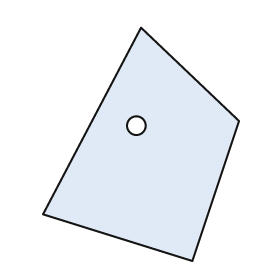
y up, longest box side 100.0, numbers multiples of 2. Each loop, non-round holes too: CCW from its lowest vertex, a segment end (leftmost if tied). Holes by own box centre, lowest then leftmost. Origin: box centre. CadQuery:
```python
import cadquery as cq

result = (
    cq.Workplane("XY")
    .moveTo(22.0, -50.0)
    .lineTo(42.0, 10.0)
    .lineTo(0.0, 50.0)
    .lineTo(-42.0, -30.0)
    .close()
    .moveTo(-2.0, 8.0)
    .circle(4.0)
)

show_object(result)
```